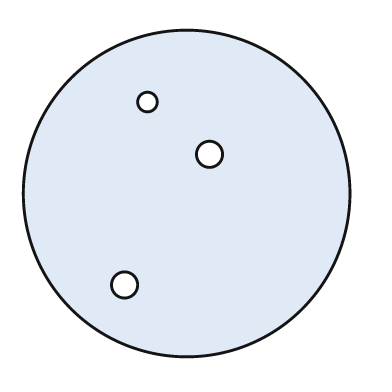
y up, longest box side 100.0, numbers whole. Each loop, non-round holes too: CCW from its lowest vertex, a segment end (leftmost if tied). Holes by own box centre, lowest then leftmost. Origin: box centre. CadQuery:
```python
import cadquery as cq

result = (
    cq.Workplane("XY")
    .moveTo(0.0, 0.0)
    .circle(50.0)
    .moveTo(-19.0, -28.0)
    .circle(4.0)
    .moveTo(7.0, 12.0)
    .circle(4.0)
    .moveTo(-12.0, 28.0)
    .circle(3.0)
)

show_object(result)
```